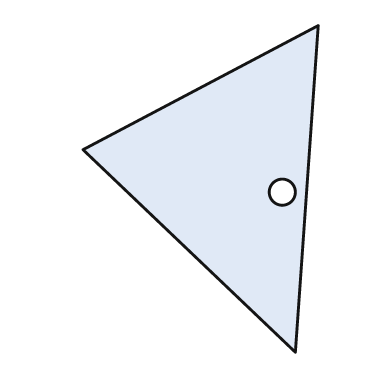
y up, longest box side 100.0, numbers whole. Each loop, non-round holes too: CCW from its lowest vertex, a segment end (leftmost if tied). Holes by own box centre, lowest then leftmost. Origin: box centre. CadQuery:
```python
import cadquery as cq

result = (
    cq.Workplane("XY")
    .moveTo(29.0, -50.0)
    .lineTo(36.0, 50.0)
    .lineTo(-36.0, 12.0)
    .close()
    .moveTo(25.0, -1.0)
    .circle(4.0)
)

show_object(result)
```